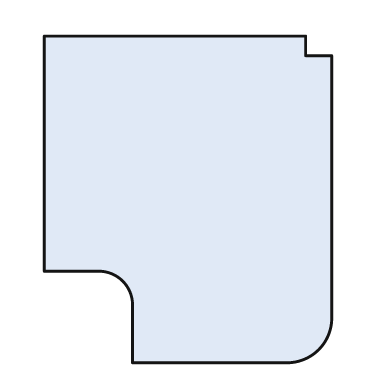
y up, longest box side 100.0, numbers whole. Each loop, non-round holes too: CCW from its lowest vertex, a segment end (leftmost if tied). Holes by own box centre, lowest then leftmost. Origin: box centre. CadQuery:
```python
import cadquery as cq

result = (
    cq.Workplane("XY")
    .moveTo(-17.0, -50.0)
    .lineTo(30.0, -50.0)
    .threePointArc((40.0, -46.0), (44.0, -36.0))
    .lineTo(44.0, 44.0)
    .lineTo(36.0, 44.0)
    .lineTo(36.0, 50.0)
    .lineTo(-44.0, 50.0)
    .lineTo(-44.0, -22.0)
    .lineTo(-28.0, -22.0)
    .threePointArc((-20.0, -25.0), (-17.0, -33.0))
    .close()
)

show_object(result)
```